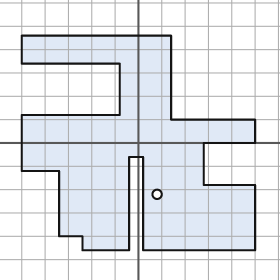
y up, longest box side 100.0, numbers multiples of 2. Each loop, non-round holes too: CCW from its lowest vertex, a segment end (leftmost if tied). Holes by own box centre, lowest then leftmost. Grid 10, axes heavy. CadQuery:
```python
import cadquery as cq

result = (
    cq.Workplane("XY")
    .moveTo(-24.0, -46.0)
    .lineTo(-4.0, -46.0)
    .lineTo(-4.0, -6.0)
    .lineTo(2.0, -6.0)
    .lineTo(2.0, -46.0)
    .lineTo(50.0, -46.0)
    .lineTo(50.0, -18.0)
    .lineTo(28.0, -18.0)
    .lineTo(28.0, 0.0)
    .lineTo(50.0, 0.0)
    .lineTo(50.0, 10.0)
    .lineTo(14.0, 10.0)
    .lineTo(14.0, 46.0)
    .lineTo(-50.0, 46.0)
    .lineTo(-50.0, 34.0)
    .lineTo(-8.0, 34.0)
    .lineTo(-8.0, 12.0)
    .lineTo(-50.0, 12.0)
    .lineTo(-50.0, -12.0)
    .lineTo(-34.0, -12.0)
    .lineTo(-34.0, -40.0)
    .lineTo(-24.0, -40.0)
    .close()
    .moveTo(8.0, -22.0)
    .circle(2.0)
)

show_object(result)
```